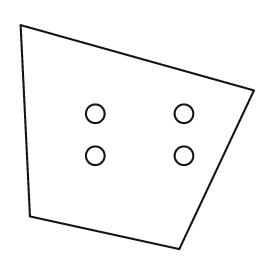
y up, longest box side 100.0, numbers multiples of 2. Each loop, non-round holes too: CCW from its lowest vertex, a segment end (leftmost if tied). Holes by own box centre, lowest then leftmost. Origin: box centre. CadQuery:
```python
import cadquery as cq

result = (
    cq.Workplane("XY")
    .moveTo(18.0, -48.0)
    .lineTo(50.0, 20.0)
    .lineTo(-50.0, 48.0)
    .lineTo(-46.0, -34.0)
    .close()
    .moveTo(-18.0, -8.0)
    .circle(4.0)
    .moveTo(20.0, -8.0)
    .circle(4.0)
    .moveTo(-18.0, 10.0)
    .circle(4.0)
    .moveTo(20.0, 10.0)
    .circle(4.0)
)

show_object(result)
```